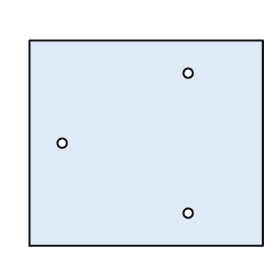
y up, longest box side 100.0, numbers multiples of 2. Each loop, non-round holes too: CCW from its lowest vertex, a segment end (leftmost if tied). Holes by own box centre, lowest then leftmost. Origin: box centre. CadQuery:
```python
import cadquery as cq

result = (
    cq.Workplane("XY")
    .moveTo(-50.0, -44.0)
    .lineTo(50.0, -44.0)
    .lineTo(50.0, 44.0)
    .lineTo(-50.0, 44.0)
    .close()
    .moveTo(18.0, -30.0)
    .circle(2.0)
    .moveTo(-36.0, 0.0)
    .circle(2.0)
    .moveTo(18.0, 30.0)
    .circle(2.0)
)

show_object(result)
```